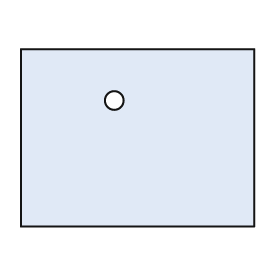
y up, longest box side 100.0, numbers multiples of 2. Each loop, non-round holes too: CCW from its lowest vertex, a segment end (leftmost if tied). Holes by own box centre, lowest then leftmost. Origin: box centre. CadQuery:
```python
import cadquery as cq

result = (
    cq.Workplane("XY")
    .moveTo(-50.0, -38.0)
    .lineTo(50.0, -38.0)
    .lineTo(50.0, 38.0)
    .lineTo(-50.0, 38.0)
    .close()
    .moveTo(-10.0, 16.0)
    .circle(4.0)
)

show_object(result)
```